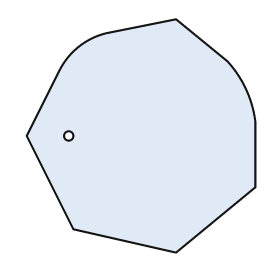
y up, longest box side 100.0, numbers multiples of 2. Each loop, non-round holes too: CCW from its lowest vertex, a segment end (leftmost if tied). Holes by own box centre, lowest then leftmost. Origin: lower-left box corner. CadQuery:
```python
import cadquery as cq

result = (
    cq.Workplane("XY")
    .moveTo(64.0, 0.0)
    .lineTo(98.0, 28.0)
    .lineTo(98.0, 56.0)
    .threePointArc((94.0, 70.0), (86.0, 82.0))
    .lineTo(64.0, 100.0)
    .lineTo(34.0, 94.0)
    .threePointArc((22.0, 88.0), (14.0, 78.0))
    .lineTo(0.0, 50.0)
    .lineTo(20.0, 10.0)
    .close()
    .moveTo(18.0, 50.0)
    .circle(2.0)
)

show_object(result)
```